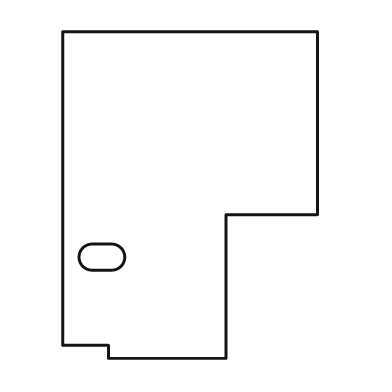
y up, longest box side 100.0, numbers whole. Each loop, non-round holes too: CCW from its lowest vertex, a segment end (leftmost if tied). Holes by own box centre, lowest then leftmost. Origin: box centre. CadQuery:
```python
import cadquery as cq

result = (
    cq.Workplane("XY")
    .moveTo(-25.0, -50.0)
    .lineTo(11.0, -50.0)
    .lineTo(11.0, -6.0)
    .lineTo(39.0, -6.0)
    .lineTo(39.0, 50.0)
    .lineTo(-39.0, 50.0)
    .lineTo(-39.0, -46.0)
    .lineTo(-25.0, -46.0)
    .close()
    .moveTo(-30.0, -23.0)
    .lineTo(-24.0, -23.0)
    .threePointArc((-20.0, -19.0), (-24.0, -15.0))
    .lineTo(-30.0, -15.0)
    .threePointArc((-34.0, -19.0), (-30.0, -23.0))
    .close()
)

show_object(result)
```